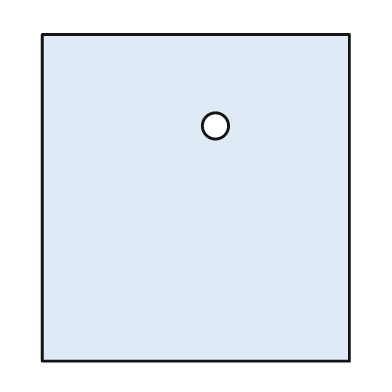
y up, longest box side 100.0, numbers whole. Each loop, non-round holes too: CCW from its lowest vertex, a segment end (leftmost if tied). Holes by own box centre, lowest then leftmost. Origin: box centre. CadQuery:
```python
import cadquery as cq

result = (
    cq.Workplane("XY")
    .moveTo(-47.0, -50.0)
    .lineTo(47.0, -50.0)
    .lineTo(47.0, 50.0)
    .lineTo(-47.0, 50.0)
    .close()
    .moveTo(6.0, 22.0)
    .circle(4.0)
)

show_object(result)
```